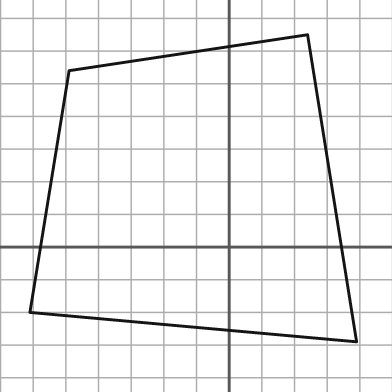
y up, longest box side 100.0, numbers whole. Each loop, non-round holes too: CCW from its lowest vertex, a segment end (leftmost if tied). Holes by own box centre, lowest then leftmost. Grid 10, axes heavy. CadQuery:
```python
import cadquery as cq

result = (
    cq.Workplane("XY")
    .moveTo(39.0, -29.0)
    .lineTo(24.0, 65.0)
    .lineTo(-49.0, 54.0)
    .lineTo(-61.0, -20.0)
    .close()
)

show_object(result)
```